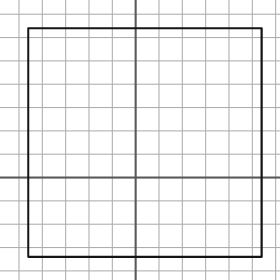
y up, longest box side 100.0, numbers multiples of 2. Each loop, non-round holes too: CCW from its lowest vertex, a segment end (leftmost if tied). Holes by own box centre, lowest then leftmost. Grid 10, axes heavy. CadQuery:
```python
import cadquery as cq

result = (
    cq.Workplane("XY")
    .moveTo(-46.0, -34.0)
    .lineTo(54.0, -34.0)
    .lineTo(54.0, 64.0)
    .lineTo(-46.0, 64.0)
    .close()
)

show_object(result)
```